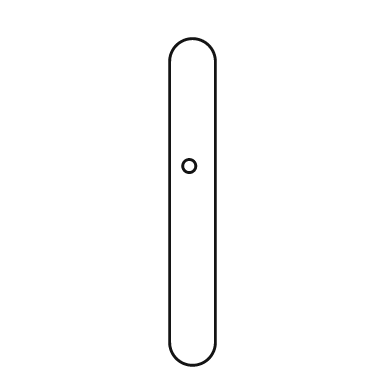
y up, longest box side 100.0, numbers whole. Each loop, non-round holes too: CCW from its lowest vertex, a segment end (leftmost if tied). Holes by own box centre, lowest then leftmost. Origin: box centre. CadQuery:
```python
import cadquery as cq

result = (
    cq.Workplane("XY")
    .moveTo(-7.0, -43.0)
    .threePointArc((0.0, -50.0), (7.0, -43.0))
    .lineTo(7.0, 43.0)
    .threePointArc((0.0, 50.0), (-7.0, 43.0))
    .close()
    .moveTo(-1.0, 11.0)
    .circle(2.0)
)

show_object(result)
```